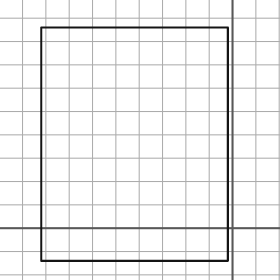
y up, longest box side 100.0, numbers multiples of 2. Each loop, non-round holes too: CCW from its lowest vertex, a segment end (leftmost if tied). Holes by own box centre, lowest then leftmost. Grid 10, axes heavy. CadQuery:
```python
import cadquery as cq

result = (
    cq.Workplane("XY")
    .moveTo(-82.0, -14.0)
    .lineTo(-2.0, -14.0)
    .lineTo(-2.0, 86.0)
    .lineTo(-82.0, 86.0)
    .close()
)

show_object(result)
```